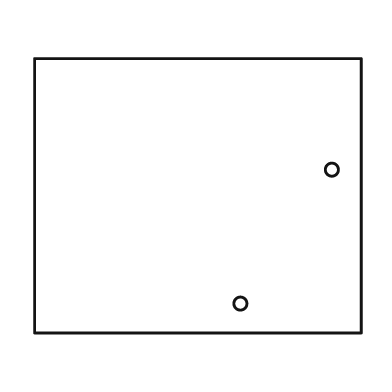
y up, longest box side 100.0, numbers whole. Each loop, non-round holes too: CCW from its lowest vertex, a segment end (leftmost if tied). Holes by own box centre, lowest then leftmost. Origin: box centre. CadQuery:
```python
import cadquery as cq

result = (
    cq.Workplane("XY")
    .moveTo(-50.0, -42.0)
    .lineTo(50.0, -42.0)
    .lineTo(50.0, 42.0)
    .lineTo(-50.0, 42.0)
    .close()
    .moveTo(13.0, -33.0)
    .circle(2.0)
    .moveTo(41.0, 8.0)
    .circle(2.0)
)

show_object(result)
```